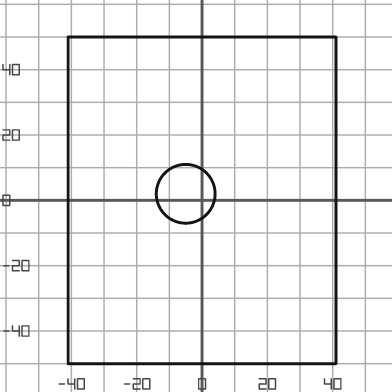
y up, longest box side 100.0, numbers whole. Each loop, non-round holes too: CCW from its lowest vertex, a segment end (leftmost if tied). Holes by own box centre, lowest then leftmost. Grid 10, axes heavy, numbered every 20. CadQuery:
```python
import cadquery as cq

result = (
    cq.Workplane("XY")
    .moveTo(-41.0, -50.0)
    .lineTo(41.0, -50.0)
    .lineTo(41.0, 50.0)
    .lineTo(-41.0, 50.0)
    .close()
    .moveTo(-5.0, 2.0)
    .circle(9.0)
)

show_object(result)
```